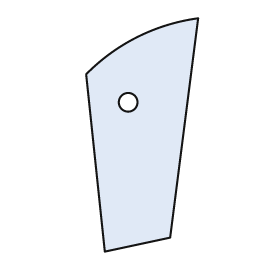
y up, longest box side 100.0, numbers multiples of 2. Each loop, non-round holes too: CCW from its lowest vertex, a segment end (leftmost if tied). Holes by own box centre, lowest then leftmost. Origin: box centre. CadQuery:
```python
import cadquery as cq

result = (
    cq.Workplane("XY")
    .moveTo(-16.0, -50.0)
    .lineTo(12.0, -44.0)
    .lineTo(24.0, 50.0)
    .threePointArc((-2.0, 42.0), (-24.0, 26.0))
    .close()
    .moveTo(-6.0, 14.0)
    .circle(4.0)
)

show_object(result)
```